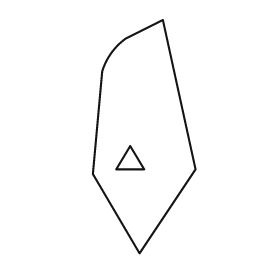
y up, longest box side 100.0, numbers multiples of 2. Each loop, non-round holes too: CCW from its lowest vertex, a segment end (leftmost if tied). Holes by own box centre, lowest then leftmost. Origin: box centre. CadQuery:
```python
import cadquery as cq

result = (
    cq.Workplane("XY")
    .moveTo(-2.0, -50.0)
    .lineTo(22.0, -14.0)
    .lineTo(8.0, 50.0)
    .lineTo(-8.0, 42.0)
    .threePointArc((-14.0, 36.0), (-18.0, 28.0))
    .lineTo(-22.0, -16.0)
    .close()
    .moveTo(-12.0, -14.0)
    .lineTo(0.0, -14.0)
    .lineTo(-6.0, -4.0)
    .close()
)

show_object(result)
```